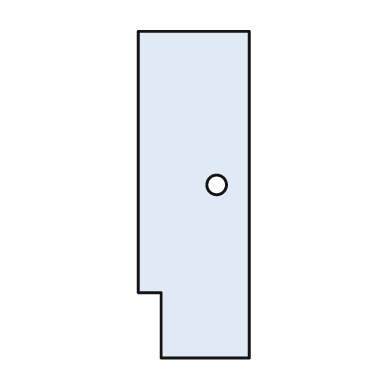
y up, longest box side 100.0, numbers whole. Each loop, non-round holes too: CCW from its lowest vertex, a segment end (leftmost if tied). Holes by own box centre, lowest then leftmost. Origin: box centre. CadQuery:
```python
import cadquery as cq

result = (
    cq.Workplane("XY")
    .moveTo(-10.0, -50.0)
    .lineTo(17.0, -50.0)
    .lineTo(17.0, 50.0)
    .lineTo(-17.0, 50.0)
    .lineTo(-17.0, -30.0)
    .lineTo(-10.0, -30.0)
    .close()
    .moveTo(7.0, 3.0)
    .circle(3.0)
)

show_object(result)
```